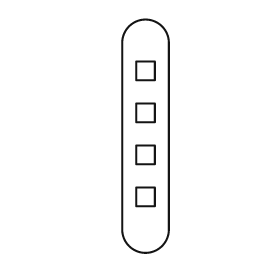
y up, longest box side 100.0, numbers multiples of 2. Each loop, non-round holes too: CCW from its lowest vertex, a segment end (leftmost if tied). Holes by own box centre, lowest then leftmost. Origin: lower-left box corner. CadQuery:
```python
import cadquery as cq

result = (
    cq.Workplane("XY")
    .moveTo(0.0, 10.0)
    .threePointArc((10.0, 0.0), (20.0, 10.0))
    .lineTo(20.0, 90.0)
    .threePointArc((10.0, 100.0), (0.0, 90.0))
    .close()
    .moveTo(6.0, 20.0)
    .lineTo(14.0, 20.0)
    .lineTo(14.0, 28.0)
    .lineTo(6.0, 28.0)
    .close()
    .moveTo(6.0, 38.0)
    .lineTo(14.0, 38.0)
    .lineTo(14.0, 46.0)
    .lineTo(6.0, 46.0)
    .close()
    .moveTo(6.0, 56.0)
    .lineTo(14.0, 56.0)
    .lineTo(14.0, 64.0)
    .lineTo(6.0, 64.0)
    .close()
    .moveTo(6.0, 74.0)
    .lineTo(14.0, 74.0)
    .lineTo(14.0, 82.0)
    .lineTo(6.0, 82.0)
    .close()
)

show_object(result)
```